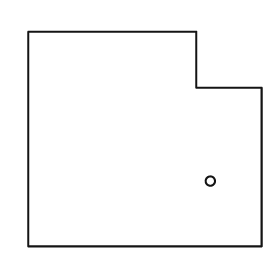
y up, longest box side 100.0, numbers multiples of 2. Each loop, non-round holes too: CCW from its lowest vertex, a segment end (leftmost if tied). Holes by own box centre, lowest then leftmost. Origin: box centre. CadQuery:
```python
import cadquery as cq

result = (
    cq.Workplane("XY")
    .moveTo(-50.0, -46.0)
    .lineTo(50.0, -46.0)
    .lineTo(50.0, 22.0)
    .lineTo(22.0, 22.0)
    .lineTo(22.0, 46.0)
    .lineTo(-50.0, 46.0)
    .close()
    .moveTo(28.0, -18.0)
    .circle(2.0)
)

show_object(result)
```